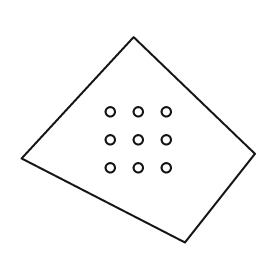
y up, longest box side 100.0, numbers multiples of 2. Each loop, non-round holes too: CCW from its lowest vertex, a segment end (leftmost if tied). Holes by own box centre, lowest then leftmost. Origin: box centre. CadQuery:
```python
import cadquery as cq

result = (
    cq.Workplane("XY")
    .moveTo(20.0, -44.0)
    .lineTo(50.0, -6.0)
    .lineTo(-2.0, 44.0)
    .lineTo(-50.0, -8.0)
    .close()
    .moveTo(-12.0, -12.0)
    .circle(2.0)
    .moveTo(0.0, -12.0)
    .circle(2.0)
    .moveTo(12.0, -12.0)
    .circle(2.0)
    .moveTo(-12.0, 0.0)
    .circle(2.0)
    .moveTo(0.0, 0.0)
    .circle(2.0)
    .moveTo(12.0, 0.0)
    .circle(2.0)
    .moveTo(-12.0, 12.0)
    .circle(2.0)
    .moveTo(0.0, 12.0)
    .circle(2.0)
    .moveTo(12.0, 12.0)
    .circle(2.0)
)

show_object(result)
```